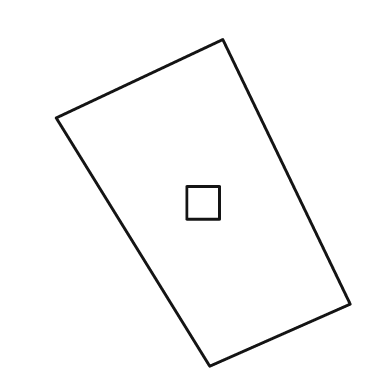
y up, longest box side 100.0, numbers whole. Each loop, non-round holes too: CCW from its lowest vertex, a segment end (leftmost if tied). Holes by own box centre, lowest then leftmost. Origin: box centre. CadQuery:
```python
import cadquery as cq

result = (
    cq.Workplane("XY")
    .moveTo(2.0, -50.0)
    .lineTo(45.0, -31.0)
    .lineTo(6.0, 50.0)
    .lineTo(-45.0, 26.0)
    .close()
    .moveTo(-5.0, -5.0)
    .lineTo(5.0, -5.0)
    .lineTo(5.0, 5.0)
    .lineTo(-5.0, 5.0)
    .close()
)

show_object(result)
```